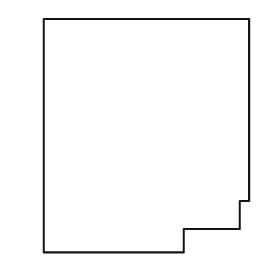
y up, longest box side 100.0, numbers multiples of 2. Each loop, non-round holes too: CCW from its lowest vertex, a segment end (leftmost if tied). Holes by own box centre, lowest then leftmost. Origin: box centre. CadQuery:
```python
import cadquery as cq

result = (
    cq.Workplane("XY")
    .moveTo(-44.0, -50.0)
    .lineTo(16.0, -50.0)
    .lineTo(16.0, -40.0)
    .lineTo(40.0, -40.0)
    .lineTo(40.0, -28.0)
    .lineTo(44.0, -28.0)
    .lineTo(44.0, 50.0)
    .lineTo(-44.0, 50.0)
    .close()
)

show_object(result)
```